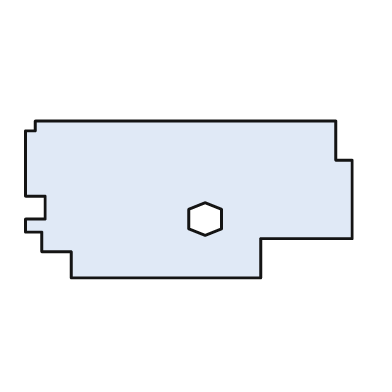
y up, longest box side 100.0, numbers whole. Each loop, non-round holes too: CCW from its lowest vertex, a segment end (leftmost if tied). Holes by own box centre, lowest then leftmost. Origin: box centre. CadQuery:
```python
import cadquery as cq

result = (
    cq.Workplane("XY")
    .moveTo(-36.0, -24.0)
    .lineTo(22.0, -24.0)
    .lineTo(22.0, -12.0)
    .lineTo(50.0, -12.0)
    .lineTo(50.0, 12.0)
    .lineTo(45.0, 12.0)
    .lineTo(45.0, 24.0)
    .lineTo(-47.0, 24.0)
    .lineTo(-47.0, 21.0)
    .lineTo(-50.0, 21.0)
    .lineTo(-50.0, 1.0)
    .lineTo(-44.0, 1.0)
    .lineTo(-44.0, -6.0)
    .lineTo(-50.0, -6.0)
    .lineTo(-50.0, -10.0)
    .lineTo(-45.0, -10.0)
    .lineTo(-45.0, -16.0)
    .lineTo(-36.0, -16.0)
    .close()
    .moveTo(5.0, -11.0)
    .lineTo(10.0, -9.0)
    .lineTo(10.0, -3.0)
    .lineTo(5.0, -1.0)
    .lineTo(0.0, -3.0)
    .lineTo(0.0, -9.0)
    .close()
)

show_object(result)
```